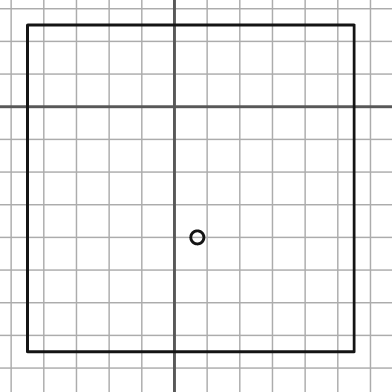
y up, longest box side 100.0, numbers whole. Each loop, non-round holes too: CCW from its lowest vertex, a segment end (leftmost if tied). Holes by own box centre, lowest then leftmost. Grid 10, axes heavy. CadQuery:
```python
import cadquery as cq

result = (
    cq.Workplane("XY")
    .moveTo(-45.0, -75.0)
    .lineTo(55.0, -75.0)
    .lineTo(55.0, 25.0)
    .lineTo(-45.0, 25.0)
    .close()
    .moveTo(7.0, -40.0)
    .circle(2.0)
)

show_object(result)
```